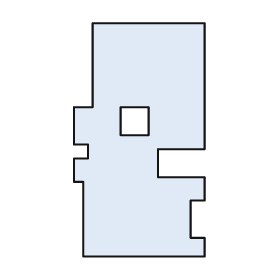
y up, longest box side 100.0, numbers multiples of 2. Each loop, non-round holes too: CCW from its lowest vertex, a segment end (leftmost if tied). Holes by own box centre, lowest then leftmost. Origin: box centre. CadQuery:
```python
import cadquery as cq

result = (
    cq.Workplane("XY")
    .moveTo(-24.0, -50.0)
    .lineTo(28.0, -50.0)
    .lineTo(28.0, -42.0)
    .lineTo(22.0, -42.0)
    .lineTo(22.0, -26.0)
    .lineTo(28.0, -26.0)
    .lineTo(28.0, -16.0)
    .lineTo(8.0, -16.0)
    .lineTo(8.0, -4.0)
    .lineTo(28.0, -4.0)
    .lineTo(28.0, 50.0)
    .lineTo(-20.0, 50.0)
    .lineTo(-20.0, 14.0)
    .lineTo(-28.0, 14.0)
    .lineTo(-28.0, -2.0)
    .lineTo(-22.0, -2.0)
    .lineTo(-22.0, -8.0)
    .lineTo(-28.0, -8.0)
    .lineTo(-28.0, -18.0)
    .lineTo(-24.0, -18.0)
    .close()
    .moveTo(-8.0, 2.0)
    .lineTo(4.0, 2.0)
    .lineTo(4.0, 14.0)
    .lineTo(-8.0, 14.0)
    .close()
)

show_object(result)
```